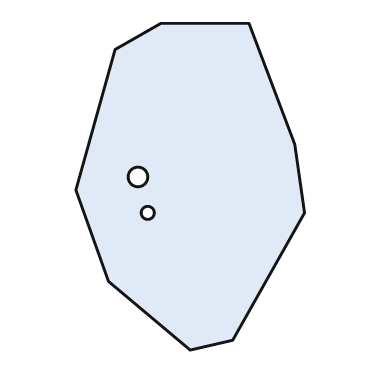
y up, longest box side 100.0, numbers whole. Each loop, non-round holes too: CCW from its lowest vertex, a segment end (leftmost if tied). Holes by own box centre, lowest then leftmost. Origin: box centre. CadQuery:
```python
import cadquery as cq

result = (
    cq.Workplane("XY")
    .moveTo(0.0, -50.0)
    .lineTo(13.0, -47.0)
    .lineTo(35.0, -8.0)
    .lineTo(32.0, 13.0)
    .lineTo(18.0, 50.0)
    .lineTo(-9.0, 50.0)
    .lineTo(-23.0, 42.0)
    .lineTo(-35.0, -1.0)
    .lineTo(-25.0, -29.0)
    .close()
    .moveTo(-13.0, -8.0)
    .circle(2.0)
    .moveTo(-16.0, 3.0)
    .circle(3.0)
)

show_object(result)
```